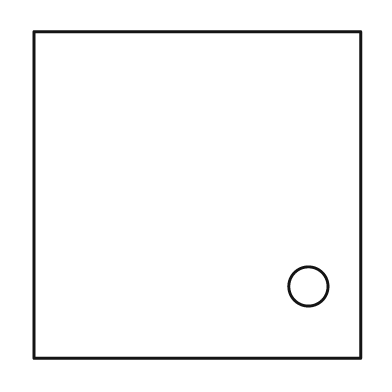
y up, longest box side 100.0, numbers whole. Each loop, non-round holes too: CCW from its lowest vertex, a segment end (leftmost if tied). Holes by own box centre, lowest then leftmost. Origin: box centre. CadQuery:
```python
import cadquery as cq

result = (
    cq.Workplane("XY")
    .moveTo(-50.0, -50.0)
    .lineTo(50.0, -50.0)
    .lineTo(50.0, 50.0)
    .lineTo(-50.0, 50.0)
    .close()
    .moveTo(34.0, -28.0)
    .circle(6.0)
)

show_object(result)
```